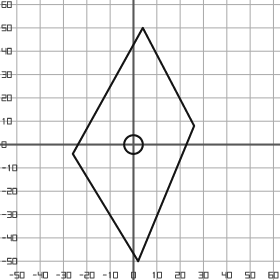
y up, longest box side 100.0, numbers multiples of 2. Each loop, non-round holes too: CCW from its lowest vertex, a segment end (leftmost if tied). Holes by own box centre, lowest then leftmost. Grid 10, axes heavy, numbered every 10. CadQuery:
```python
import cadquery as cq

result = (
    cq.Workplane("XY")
    .moveTo(2.0, -50.0)
    .lineTo(26.0, 8.0)
    .lineTo(4.0, 50.0)
    .lineTo(-26.0, -4.0)
    .close()
    .moveTo(0.0, 0.0)
    .circle(4.0)
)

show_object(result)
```